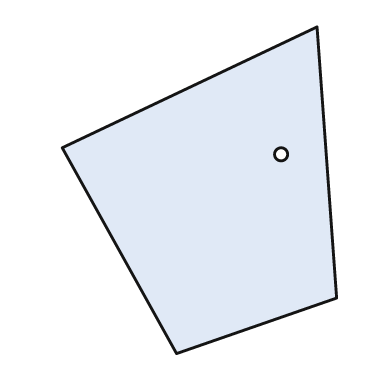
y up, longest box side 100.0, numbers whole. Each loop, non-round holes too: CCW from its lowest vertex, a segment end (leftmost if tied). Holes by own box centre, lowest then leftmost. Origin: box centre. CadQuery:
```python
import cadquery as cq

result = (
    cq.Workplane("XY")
    .moveTo(-7.0, -50.0)
    .lineTo(42.0, -33.0)
    .lineTo(36.0, 50.0)
    .lineTo(-42.0, 13.0)
    .close()
    .moveTo(25.0, 11.0)
    .circle(2.0)
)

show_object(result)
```